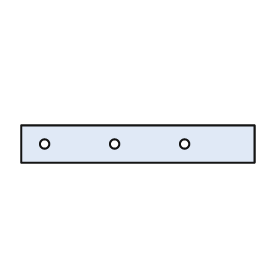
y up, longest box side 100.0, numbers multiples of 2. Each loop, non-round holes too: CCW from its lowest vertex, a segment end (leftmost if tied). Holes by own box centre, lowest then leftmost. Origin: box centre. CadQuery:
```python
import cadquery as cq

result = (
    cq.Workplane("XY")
    .moveTo(-50.0, -8.0)
    .lineTo(50.0, -8.0)
    .lineTo(50.0, 8.0)
    .lineTo(-50.0, 8.0)
    .close()
    .moveTo(-40.0, 0.0)
    .circle(2.0)
    .moveTo(-10.0, 0.0)
    .circle(2.0)
    .moveTo(20.0, 0.0)
    .circle(2.0)
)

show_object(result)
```